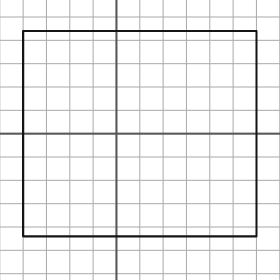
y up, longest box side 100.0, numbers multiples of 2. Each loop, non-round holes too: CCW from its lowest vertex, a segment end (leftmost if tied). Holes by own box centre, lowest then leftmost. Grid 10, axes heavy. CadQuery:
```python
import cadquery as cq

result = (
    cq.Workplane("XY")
    .moveTo(-40.0, -44.0)
    .lineTo(60.0, -44.0)
    .lineTo(60.0, 44.0)
    .lineTo(-40.0, 44.0)
    .close()
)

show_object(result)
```